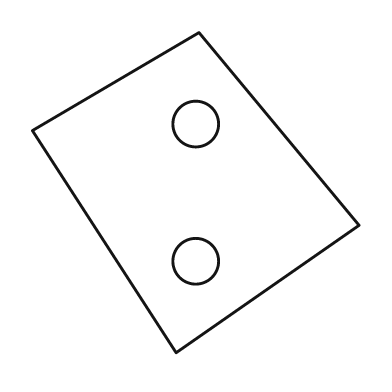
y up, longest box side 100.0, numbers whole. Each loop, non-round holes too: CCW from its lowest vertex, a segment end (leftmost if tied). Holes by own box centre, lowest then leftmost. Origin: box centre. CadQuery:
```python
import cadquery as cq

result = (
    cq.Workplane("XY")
    .moveTo(-6.0, -49.0)
    .lineTo(50.0, -10.0)
    .lineTo(1.0, 49.0)
    .lineTo(-50.0, 19.0)
    .close()
    .moveTo(0.0, -21.0)
    .circle(7.0)
    .moveTo(0.0, 21.0)
    .circle(7.0)
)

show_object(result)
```